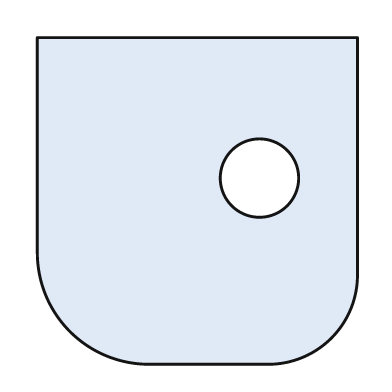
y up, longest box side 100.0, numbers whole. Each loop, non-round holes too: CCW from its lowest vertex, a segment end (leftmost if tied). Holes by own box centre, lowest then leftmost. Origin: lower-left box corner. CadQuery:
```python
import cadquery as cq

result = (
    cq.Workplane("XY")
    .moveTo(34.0, 0.0)
    .lineTo(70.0, 0.0)
    .threePointArc((90.0, 8.0), (98.0, 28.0))
    .lineTo(98.0, 100.0)
    .lineTo(0.0, 100.0)
    .lineTo(0.0, 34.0)
    .threePointArc((10.0, 10.0), (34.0, 0.0))
    .close()
    .moveTo(68.0, 57.0)
    .circle(12.0)
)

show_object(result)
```